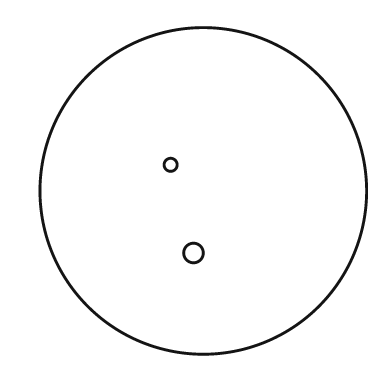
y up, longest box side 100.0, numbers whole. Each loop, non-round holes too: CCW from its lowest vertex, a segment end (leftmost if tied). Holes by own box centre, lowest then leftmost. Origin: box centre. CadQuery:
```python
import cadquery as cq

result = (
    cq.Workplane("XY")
    .moveTo(0.0, 0.0)
    .circle(50.0)
    .moveTo(-3.0, -19.0)
    .circle(3.0)
    .moveTo(-10.0, 8.0)
    .circle(2.0)
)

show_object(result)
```